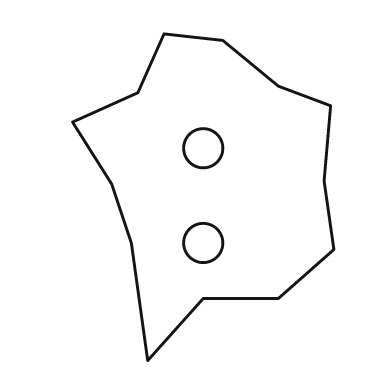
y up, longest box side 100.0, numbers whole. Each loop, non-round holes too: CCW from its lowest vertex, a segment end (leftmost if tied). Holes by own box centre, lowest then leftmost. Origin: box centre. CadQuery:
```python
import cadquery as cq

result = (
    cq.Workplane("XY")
    .moveTo(-17.0, -50.0)
    .lineTo(0.0, -31.0)
    .lineTo(23.0, -31.0)
    .lineTo(40.0, -16.0)
    .lineTo(37.0, 5.0)
    .lineTo(39.0, 28.0)
    .lineTo(23.0, 34.0)
    .lineTo(6.0, 48.0)
    .lineTo(-12.0, 50.0)
    .lineTo(-20.0, 32.0)
    .lineTo(-40.0, 23.0)
    .lineTo(-28.0, 4.0)
    .lineTo(-22.0, -14.0)
    .close()
    .moveTo(0.0, -14.0)
    .circle(6.0)
    .moveTo(0.0, 15.0)
    .circle(6.0)
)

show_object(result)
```